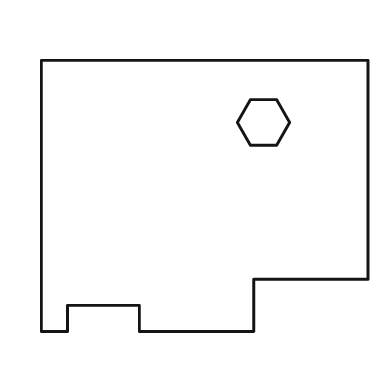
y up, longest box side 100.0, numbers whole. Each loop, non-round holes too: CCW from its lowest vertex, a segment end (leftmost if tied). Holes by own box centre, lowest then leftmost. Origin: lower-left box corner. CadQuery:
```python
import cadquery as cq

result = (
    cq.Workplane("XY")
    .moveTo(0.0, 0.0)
    .lineTo(8.0, 0.0)
    .lineTo(8.0, 8.0)
    .lineTo(30.0, 8.0)
    .lineTo(30.0, 0.0)
    .lineTo(65.0, 0.0)
    .lineTo(65.0, 16.0)
    .lineTo(100.0, 16.0)
    .lineTo(100.0, 83.0)
    .lineTo(0.0, 83.0)
    .close()
    .moveTo(64.0, 57.0)
    .lineTo(72.0, 57.0)
    .lineTo(76.0, 64.0)
    .lineTo(72.0, 71.0)
    .lineTo(64.0, 71.0)
    .lineTo(60.0, 64.0)
    .close()
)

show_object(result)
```